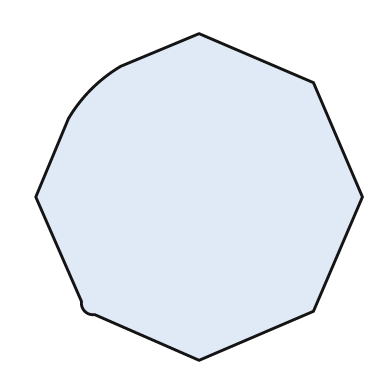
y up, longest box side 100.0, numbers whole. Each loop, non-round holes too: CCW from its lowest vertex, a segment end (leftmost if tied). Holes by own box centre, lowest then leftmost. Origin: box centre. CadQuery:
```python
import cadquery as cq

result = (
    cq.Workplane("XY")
    .moveTo(0.0, -50.0)
    .lineTo(35.0, -35.0)
    .lineTo(50.0, 0.0)
    .lineTo(35.0, 35.0)
    .lineTo(0.0, 50.0)
    .lineTo(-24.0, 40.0)
    .threePointArc((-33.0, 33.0), (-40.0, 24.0))
    .lineTo(-50.0, 0.0)
    .lineTo(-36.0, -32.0)
    .threePointArc((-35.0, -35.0), (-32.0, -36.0))
    .close()
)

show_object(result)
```